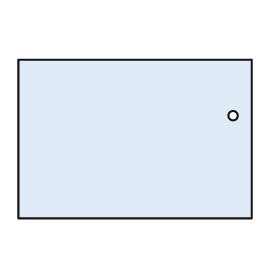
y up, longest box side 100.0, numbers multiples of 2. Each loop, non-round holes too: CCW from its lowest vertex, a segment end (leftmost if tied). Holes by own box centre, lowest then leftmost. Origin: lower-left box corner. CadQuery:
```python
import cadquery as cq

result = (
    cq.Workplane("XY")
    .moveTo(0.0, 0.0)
    .lineTo(100.0, 0.0)
    .lineTo(100.0, 68.0)
    .lineTo(0.0, 68.0)
    .close()
    .moveTo(92.0, 44.0)
    .circle(2.0)
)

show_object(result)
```